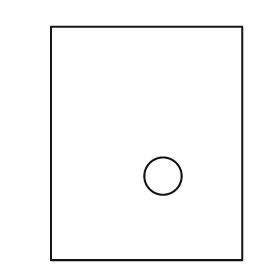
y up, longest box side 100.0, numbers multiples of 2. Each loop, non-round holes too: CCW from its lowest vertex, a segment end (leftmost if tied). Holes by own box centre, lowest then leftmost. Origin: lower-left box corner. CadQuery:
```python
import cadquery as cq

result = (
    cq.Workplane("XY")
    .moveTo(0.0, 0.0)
    .lineTo(82.0, 0.0)
    .lineTo(82.0, 100.0)
    .lineTo(0.0, 100.0)
    .close()
    .moveTo(48.0, 36.0)
    .circle(8.0)
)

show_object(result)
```